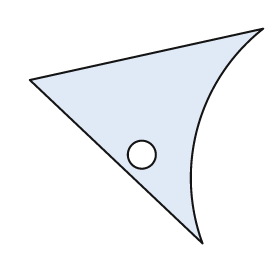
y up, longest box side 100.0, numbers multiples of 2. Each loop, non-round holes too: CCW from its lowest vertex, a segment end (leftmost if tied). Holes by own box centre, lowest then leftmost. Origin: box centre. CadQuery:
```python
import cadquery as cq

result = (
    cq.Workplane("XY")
    .moveTo(24.0, -46.0)
    .threePointArc((22.0, 4.0), (50.0, 46.0))
    .lineTo(-50.0, 24.0)
    .close()
    .moveTo(-2.0, -8.0)
    .circle(6.0)
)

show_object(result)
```